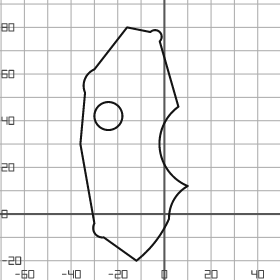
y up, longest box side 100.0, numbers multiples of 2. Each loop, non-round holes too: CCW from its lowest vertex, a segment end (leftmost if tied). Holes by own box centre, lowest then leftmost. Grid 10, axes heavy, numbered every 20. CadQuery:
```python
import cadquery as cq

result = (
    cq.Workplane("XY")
    .moveTo(-12.0, -20.0)
    .threePointArc((-4.0, -12.0), (2.0, -2.0))
    .threePointArc((4.0, 6.0), (10.0, 12.0))
    .threePointArc((-2.0, 28.0), (6.0, 46.0))
    .lineTo(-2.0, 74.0)
    .threePointArc((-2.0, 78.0), (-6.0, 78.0))
    .lineTo(-16.0, 80.0)
    .lineTo(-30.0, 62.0)
    .threePointArc((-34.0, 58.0), (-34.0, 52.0))
    .lineTo(-36.0, 30.0)
    .lineTo(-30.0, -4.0)
    .threePointArc((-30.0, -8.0), (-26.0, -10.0))
    .close()
    .moveTo(-24.0, 42.0)
    .circle(6.0)
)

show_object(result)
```